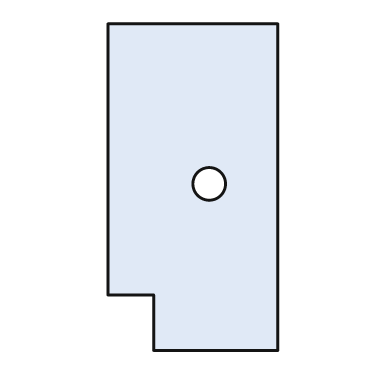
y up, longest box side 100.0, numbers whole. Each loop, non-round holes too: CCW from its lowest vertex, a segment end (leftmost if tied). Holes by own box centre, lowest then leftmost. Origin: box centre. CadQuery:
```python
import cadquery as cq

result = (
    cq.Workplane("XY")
    .moveTo(-12.0, -50.0)
    .lineTo(26.0, -50.0)
    .lineTo(26.0, 50.0)
    .lineTo(-26.0, 50.0)
    .lineTo(-26.0, -33.0)
    .lineTo(-12.0, -33.0)
    .close()
    .moveTo(5.0, 1.0)
    .circle(5.0)
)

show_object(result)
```